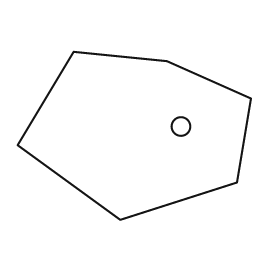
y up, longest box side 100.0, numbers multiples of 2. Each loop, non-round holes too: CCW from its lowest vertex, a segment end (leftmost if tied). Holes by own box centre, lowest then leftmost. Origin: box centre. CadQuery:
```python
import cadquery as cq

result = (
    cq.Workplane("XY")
    .moveTo(-6.0, -36.0)
    .lineTo(44.0, -20.0)
    .lineTo(50.0, 16.0)
    .lineTo(14.0, 32.0)
    .lineTo(-26.0, 36.0)
    .lineTo(-50.0, -4.0)
    .close()
    .moveTo(20.0, 4.0)
    .circle(4.0)
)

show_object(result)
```